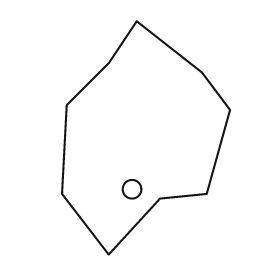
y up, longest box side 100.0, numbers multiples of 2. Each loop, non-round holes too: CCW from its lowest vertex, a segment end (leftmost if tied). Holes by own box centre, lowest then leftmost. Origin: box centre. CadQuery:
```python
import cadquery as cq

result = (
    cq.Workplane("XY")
    .moveTo(-16.0, -50.0)
    .lineTo(6.0, -26.0)
    .lineTo(26.0, -24.0)
    .lineTo(36.0, 12.0)
    .lineTo(24.0, 28.0)
    .lineTo(-4.0, 50.0)
    .lineTo(-16.0, 32.0)
    .lineTo(-34.0, 14.0)
    .lineTo(-36.0, -24.0)
    .close()
    .moveTo(-6.0, -22.0)
    .circle(4.0)
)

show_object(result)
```